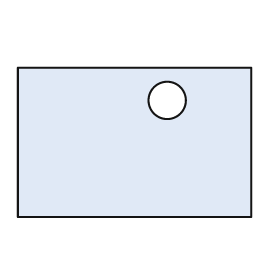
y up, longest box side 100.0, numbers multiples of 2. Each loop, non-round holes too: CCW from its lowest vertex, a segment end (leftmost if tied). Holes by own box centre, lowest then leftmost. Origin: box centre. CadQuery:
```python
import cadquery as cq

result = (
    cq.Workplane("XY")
    .moveTo(-50.0, -32.0)
    .lineTo(50.0, -32.0)
    .lineTo(50.0, 32.0)
    .lineTo(-50.0, 32.0)
    .close()
    .moveTo(14.0, 18.0)
    .circle(8.0)
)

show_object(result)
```